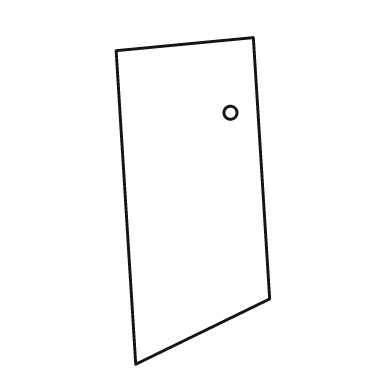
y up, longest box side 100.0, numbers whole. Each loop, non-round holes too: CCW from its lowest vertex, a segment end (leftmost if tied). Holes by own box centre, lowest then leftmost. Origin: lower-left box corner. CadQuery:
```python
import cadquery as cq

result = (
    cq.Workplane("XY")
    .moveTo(6.0, 0.0)
    .lineTo(47.0, 20.0)
    .lineTo(42.0, 100.0)
    .lineTo(0.0, 96.0)
    .close()
    .moveTo(35.0, 77.0)
    .circle(2.0)
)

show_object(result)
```